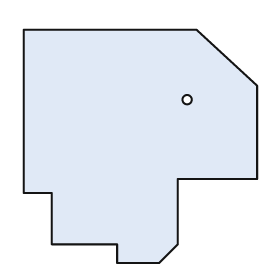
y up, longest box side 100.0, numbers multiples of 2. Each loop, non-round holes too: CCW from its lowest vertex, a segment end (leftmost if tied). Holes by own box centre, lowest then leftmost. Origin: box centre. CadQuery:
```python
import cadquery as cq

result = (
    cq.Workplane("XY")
    .moveTo(-10.0, -50.0)
    .lineTo(8.0, -50.0)
    .lineTo(16.0, -42.0)
    .lineTo(16.0, -14.0)
    .lineTo(50.0, -14.0)
    .lineTo(50.0, 26.0)
    .lineTo(24.0, 50.0)
    .lineTo(-50.0, 50.0)
    .lineTo(-50.0, -20.0)
    .lineTo(-38.0, -20.0)
    .lineTo(-38.0, -42.0)
    .lineTo(-10.0, -42.0)
    .close()
    .moveTo(20.0, 20.0)
    .circle(2.0)
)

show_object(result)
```